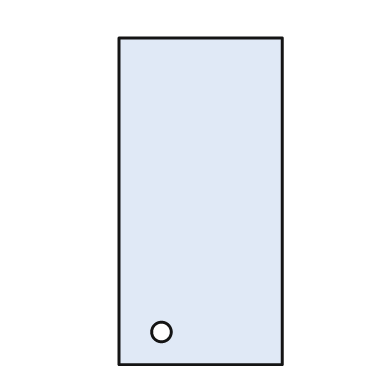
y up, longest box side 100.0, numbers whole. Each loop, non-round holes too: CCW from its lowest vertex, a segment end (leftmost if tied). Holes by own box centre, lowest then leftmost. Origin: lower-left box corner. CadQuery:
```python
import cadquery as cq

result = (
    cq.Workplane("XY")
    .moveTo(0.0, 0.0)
    .lineTo(50.0, 0.0)
    .lineTo(50.0, 100.0)
    .lineTo(0.0, 100.0)
    .close()
    .moveTo(13.0, 10.0)
    .circle(3.0)
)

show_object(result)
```